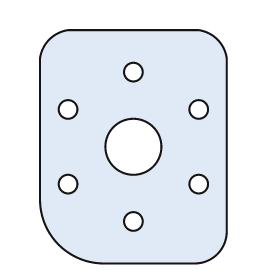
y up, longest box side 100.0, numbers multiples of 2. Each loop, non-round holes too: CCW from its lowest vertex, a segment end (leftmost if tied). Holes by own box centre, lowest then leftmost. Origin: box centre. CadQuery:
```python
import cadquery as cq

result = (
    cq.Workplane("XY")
    .moveTo(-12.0, -50.0)
    .lineTo(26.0, -50.0)
    .threePointArc((36.0, -46.0), (40.0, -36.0))
    .lineTo(40.0, 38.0)
    .threePointArc((36.0, 46.0), (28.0, 50.0))
    .lineTo(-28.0, 50.0)
    .threePointArc((-36.0, 46.0), (-40.0, 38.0))
    .lineTo(-40.0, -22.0)
    .threePointArc((-32.0, -42.0), (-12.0, -50.0))
    .close()
    .moveTo(0.0, -32.0)
    .circle(4.0)
    .moveTo(-28.0, -16.0)
    .circle(4.0)
    .moveTo(28.0, -16.0)
    .circle(4.0)
    .moveTo(0.0, 0.0)
    .circle(12.0)
    .moveTo(-28.0, 16.0)
    .circle(4.0)
    .moveTo(28.0, 16.0)
    .circle(4.0)
    .moveTo(0.0, 32.0)
    .circle(4.0)
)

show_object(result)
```